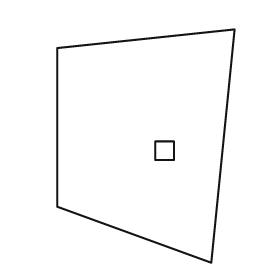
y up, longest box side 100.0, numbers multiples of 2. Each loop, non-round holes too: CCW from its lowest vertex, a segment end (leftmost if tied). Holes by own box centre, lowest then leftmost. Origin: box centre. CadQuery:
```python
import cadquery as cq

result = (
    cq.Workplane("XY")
    .moveTo(28.0, -50.0)
    .lineTo(38.0, 50.0)
    .lineTo(-38.0, 42.0)
    .lineTo(-38.0, -26.0)
    .close()
    .moveTo(4.0, -6.0)
    .lineTo(12.0, -6.0)
    .lineTo(12.0, 2.0)
    .lineTo(4.0, 2.0)
    .close()
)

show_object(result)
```